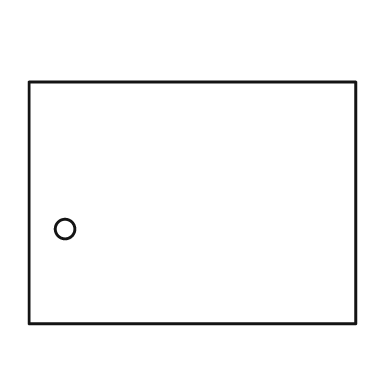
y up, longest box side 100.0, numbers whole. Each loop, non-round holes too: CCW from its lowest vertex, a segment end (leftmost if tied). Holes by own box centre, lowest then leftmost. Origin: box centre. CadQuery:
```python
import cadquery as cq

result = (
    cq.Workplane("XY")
    .moveTo(-50.0, -37.0)
    .lineTo(50.0, -37.0)
    .lineTo(50.0, 37.0)
    .lineTo(-50.0, 37.0)
    .close()
    .moveTo(-39.0, -8.0)
    .circle(3.0)
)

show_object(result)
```